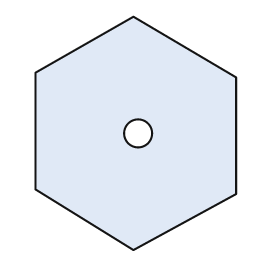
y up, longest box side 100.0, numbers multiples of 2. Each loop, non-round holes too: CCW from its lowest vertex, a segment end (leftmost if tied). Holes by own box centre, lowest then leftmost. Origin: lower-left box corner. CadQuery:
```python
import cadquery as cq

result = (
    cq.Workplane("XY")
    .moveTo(42.0, 0.0)
    .lineTo(86.0, 24.0)
    .lineTo(86.0, 74.0)
    .lineTo(42.0, 100.0)
    .lineTo(0.0, 76.0)
    .lineTo(0.0, 26.0)
    .close()
    .moveTo(44.0, 50.0)
    .circle(6.0)
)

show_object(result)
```